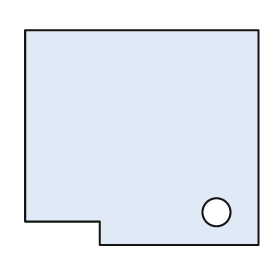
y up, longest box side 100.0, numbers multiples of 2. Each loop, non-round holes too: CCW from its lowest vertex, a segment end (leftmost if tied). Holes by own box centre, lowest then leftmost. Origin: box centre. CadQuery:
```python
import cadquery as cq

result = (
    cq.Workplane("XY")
    .moveTo(-18.0, -46.0)
    .lineTo(50.0, -46.0)
    .lineTo(50.0, 46.0)
    .lineTo(-50.0, 46.0)
    .lineTo(-50.0, -36.0)
    .lineTo(-18.0, -36.0)
    .close()
    .moveTo(32.0, -32.0)
    .circle(6.0)
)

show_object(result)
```